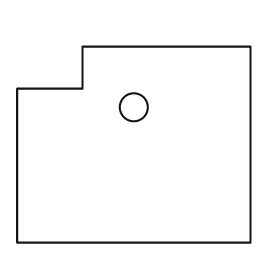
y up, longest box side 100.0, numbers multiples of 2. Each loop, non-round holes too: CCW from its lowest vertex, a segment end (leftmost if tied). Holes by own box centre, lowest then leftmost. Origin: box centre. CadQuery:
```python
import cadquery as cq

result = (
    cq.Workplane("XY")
    .moveTo(-50.0, -42.0)
    .lineTo(50.0, -42.0)
    .lineTo(50.0, 42.0)
    .lineTo(-22.0, 42.0)
    .lineTo(-22.0, 24.0)
    .lineTo(-50.0, 24.0)
    .close()
    .moveTo(0.0, 16.0)
    .circle(6.0)
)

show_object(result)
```